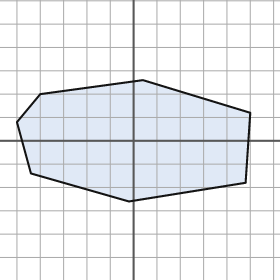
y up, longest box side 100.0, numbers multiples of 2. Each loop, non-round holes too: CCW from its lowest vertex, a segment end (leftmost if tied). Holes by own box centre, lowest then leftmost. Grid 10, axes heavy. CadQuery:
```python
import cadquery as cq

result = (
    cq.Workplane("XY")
    .moveTo(-2.0, -26.0)
    .lineTo(48.0, -18.0)
    .lineTo(50.0, 12.0)
    .lineTo(4.0, 26.0)
    .lineTo(-40.0, 20.0)
    .lineTo(-50.0, 8.0)
    .lineTo(-44.0, -14.0)
    .close()
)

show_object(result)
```